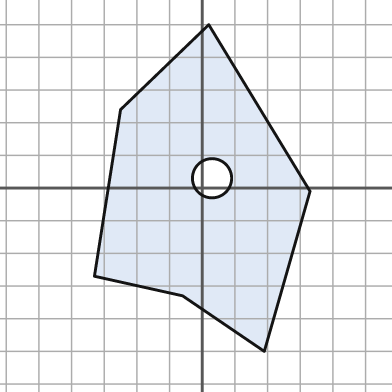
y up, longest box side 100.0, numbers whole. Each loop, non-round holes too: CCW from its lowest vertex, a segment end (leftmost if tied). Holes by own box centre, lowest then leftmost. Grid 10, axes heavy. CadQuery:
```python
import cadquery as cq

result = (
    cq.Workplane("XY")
    .moveTo(19.0, -50.0)
    .lineTo(33.0, -1.0)
    .lineTo(2.0, 50.0)
    .lineTo(-25.0, 24.0)
    .lineTo(-33.0, -27.0)
    .lineTo(-6.0, -33.0)
    .close()
    .moveTo(3.0, 3.0)
    .circle(6.0)
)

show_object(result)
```